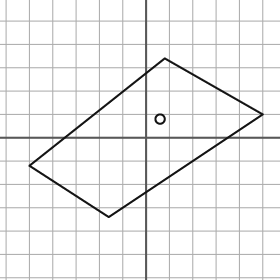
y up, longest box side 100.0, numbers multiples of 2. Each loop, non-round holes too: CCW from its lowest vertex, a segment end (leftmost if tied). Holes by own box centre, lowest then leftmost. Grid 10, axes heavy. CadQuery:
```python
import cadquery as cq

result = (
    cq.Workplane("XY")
    .moveTo(-16.0, -34.0)
    .lineTo(50.0, 10.0)
    .lineTo(8.0, 34.0)
    .lineTo(-50.0, -12.0)
    .close()
    .moveTo(6.0, 8.0)
    .circle(2.0)
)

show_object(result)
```